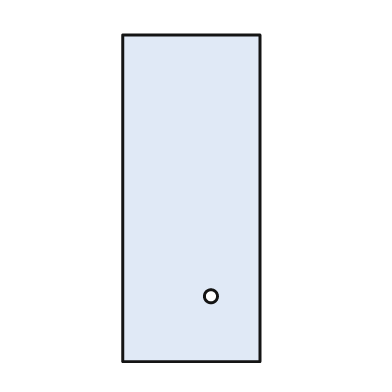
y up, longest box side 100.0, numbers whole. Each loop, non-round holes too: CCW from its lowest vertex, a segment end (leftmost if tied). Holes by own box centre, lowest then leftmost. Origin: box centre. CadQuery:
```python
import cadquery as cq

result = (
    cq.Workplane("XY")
    .moveTo(-21.0, -50.0)
    .lineTo(21.0, -50.0)
    .lineTo(21.0, 50.0)
    .lineTo(-21.0, 50.0)
    .close()
    .moveTo(6.0, -30.0)
    .circle(2.0)
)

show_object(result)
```